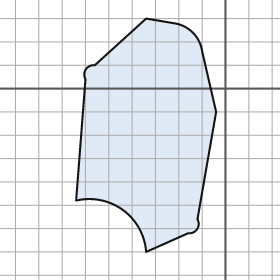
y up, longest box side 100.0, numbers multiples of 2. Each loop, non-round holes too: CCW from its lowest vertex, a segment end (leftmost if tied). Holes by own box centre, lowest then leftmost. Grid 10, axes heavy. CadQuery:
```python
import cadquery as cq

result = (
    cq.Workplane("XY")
    .moveTo(-34.0, -70.0)
    .lineTo(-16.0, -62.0)
    .threePointArc((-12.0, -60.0), (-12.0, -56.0))
    .lineTo(-4.0, -10.0)
    .lineTo(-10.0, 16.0)
    .threePointArc((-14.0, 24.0), (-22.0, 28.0))
    .lineTo(-34.0, 30.0)
    .lineTo(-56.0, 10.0)
    .threePointArc((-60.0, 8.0), (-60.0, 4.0))
    .lineTo(-64.0, -48.0)
    .threePointArc((-44.0, -52.0), (-34.0, -70.0))
    .close()
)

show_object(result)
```